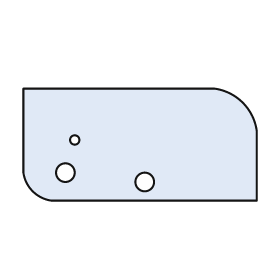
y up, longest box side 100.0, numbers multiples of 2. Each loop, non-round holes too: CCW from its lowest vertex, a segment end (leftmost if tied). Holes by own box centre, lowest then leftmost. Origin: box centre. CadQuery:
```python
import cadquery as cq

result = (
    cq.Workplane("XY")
    .moveTo(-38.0, -24.0)
    .lineTo(50.0, -24.0)
    .lineTo(50.0, 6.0)
    .threePointArc((44.0, 18.0), (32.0, 24.0))
    .lineTo(-50.0, 24.0)
    .lineTo(-50.0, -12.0)
    .threePointArc((-46.0, -20.0), (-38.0, -24.0))
    .close()
    .moveTo(2.0, -16.0)
    .circle(4.0)
    .moveTo(-32.0, -12.0)
    .circle(4.0)
    .moveTo(-28.0, 2.0)
    .circle(2.0)
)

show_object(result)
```